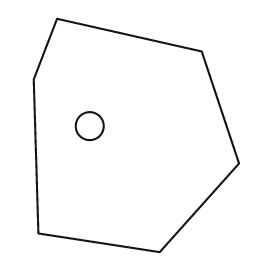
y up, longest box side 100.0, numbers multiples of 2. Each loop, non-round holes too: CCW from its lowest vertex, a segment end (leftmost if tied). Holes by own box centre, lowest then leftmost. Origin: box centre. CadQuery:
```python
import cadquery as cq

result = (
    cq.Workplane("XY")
    .moveTo(10.0, -50.0)
    .lineTo(44.0, -12.0)
    .lineTo(28.0, 36.0)
    .lineTo(-34.0, 50.0)
    .lineTo(-44.0, 24.0)
    .lineTo(-42.0, -42.0)
    .close()
    .moveTo(-20.0, 4.0)
    .circle(6.0)
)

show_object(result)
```